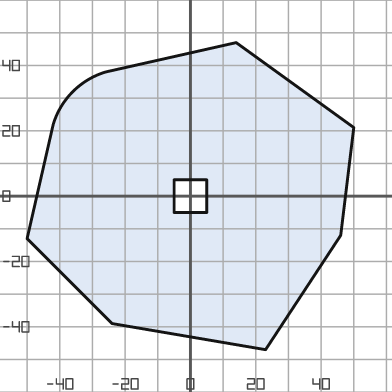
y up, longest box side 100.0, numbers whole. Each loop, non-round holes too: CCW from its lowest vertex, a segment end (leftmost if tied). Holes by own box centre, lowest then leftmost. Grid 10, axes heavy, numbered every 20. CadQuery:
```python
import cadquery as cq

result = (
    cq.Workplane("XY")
    .moveTo(23.0, -47.0)
    .lineTo(46.0, -12.0)
    .lineTo(50.0, 21.0)
    .lineTo(14.0, 47.0)
    .lineTo(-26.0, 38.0)
    .threePointArc((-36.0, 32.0), (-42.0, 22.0))
    .lineTo(-50.0, -13.0)
    .lineTo(-24.0, -39.0)
    .close()
    .moveTo(-5.0, -5.0)
    .lineTo(5.0, -5.0)
    .lineTo(5.0, 5.0)
    .lineTo(-5.0, 5.0)
    .close()
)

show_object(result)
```